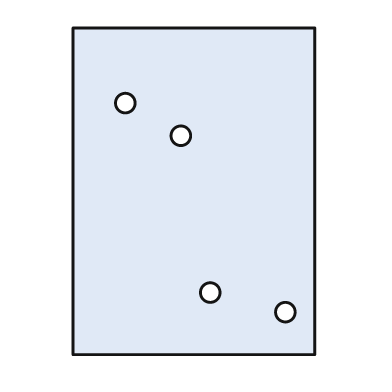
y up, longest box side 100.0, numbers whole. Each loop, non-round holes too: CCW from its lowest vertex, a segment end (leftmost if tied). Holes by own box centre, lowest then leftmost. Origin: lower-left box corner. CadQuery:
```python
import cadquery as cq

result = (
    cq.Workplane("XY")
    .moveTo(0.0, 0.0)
    .lineTo(74.0, 0.0)
    .lineTo(74.0, 100.0)
    .lineTo(0.0, 100.0)
    .close()
    .moveTo(65.0, 13.0)
    .circle(3.0)
    .moveTo(42.0, 19.0)
    .circle(3.0)
    .moveTo(33.0, 67.0)
    .circle(3.0)
    .moveTo(16.0, 77.0)
    .circle(3.0)
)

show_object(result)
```